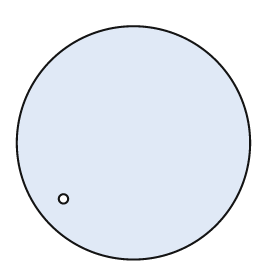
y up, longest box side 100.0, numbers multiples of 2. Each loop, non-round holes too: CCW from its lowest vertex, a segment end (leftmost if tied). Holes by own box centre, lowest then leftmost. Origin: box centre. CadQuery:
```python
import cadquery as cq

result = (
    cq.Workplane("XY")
    .moveTo(0.0, 0.0)
    .circle(50.0)
    .moveTo(-30.0, -24.0)
    .circle(2.0)
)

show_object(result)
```